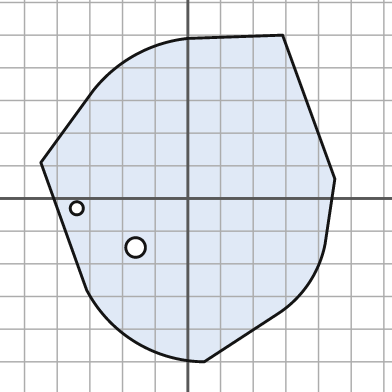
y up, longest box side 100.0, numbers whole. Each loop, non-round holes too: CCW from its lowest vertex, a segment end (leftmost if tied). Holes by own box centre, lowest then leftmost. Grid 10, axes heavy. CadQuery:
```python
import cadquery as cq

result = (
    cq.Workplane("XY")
    .moveTo(5.0, -50.0)
    .lineTo(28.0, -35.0)
    .threePointArc((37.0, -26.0), (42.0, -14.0))
    .lineTo(45.0, 6.0)
    .lineTo(29.0, 50.0)
    .lineTo(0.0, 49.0)
    .threePointArc((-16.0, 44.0), (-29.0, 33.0))
    .lineTo(-45.0, 11.0)
    .lineTo(-31.0, -28.0)
    .threePointArc((-16.0, -44.0), (5.0, -50.0))
    .close()
    .moveTo(-16.0, -15.0)
    .circle(3.0)
    .moveTo(-34.0, -3.0)
    .circle(2.0)
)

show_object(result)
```